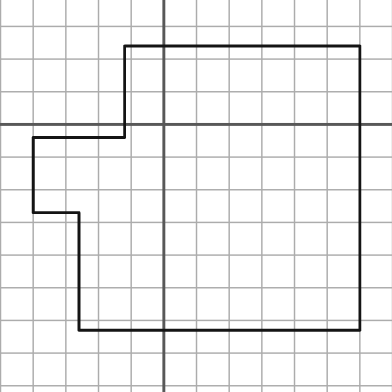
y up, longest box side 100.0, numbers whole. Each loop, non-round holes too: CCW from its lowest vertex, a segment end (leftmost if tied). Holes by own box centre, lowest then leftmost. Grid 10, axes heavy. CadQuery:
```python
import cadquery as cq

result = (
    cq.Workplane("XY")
    .moveTo(-26.0, -63.0)
    .lineTo(60.0, -63.0)
    .lineTo(60.0, 24.0)
    .lineTo(-12.0, 24.0)
    .lineTo(-12.0, -4.0)
    .lineTo(-40.0, -4.0)
    .lineTo(-40.0, -27.0)
    .lineTo(-26.0, -27.0)
    .close()
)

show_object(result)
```